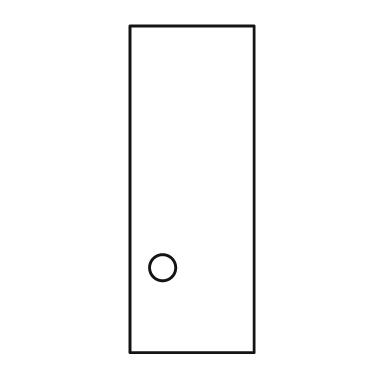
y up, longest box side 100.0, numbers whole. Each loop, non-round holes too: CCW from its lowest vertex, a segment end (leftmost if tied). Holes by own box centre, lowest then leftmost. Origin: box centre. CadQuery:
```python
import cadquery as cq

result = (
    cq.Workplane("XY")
    .moveTo(-19.0, -50.0)
    .lineTo(19.0, -50.0)
    .lineTo(19.0, 50.0)
    .lineTo(-19.0, 50.0)
    .close()
    .moveTo(-9.0, -24.0)
    .circle(4.0)
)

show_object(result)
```